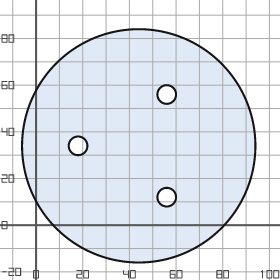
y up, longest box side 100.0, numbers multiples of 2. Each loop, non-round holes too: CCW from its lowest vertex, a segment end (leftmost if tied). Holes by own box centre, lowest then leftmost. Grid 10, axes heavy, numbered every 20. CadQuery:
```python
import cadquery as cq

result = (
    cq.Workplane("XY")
    .moveTo(44.0, 34.0)
    .circle(50.0)
    .moveTo(56.0, 12.0)
    .circle(4.0)
    .moveTo(18.0, 34.0)
    .circle(4.0)
    .moveTo(56.0, 56.0)
    .circle(4.0)
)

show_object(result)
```